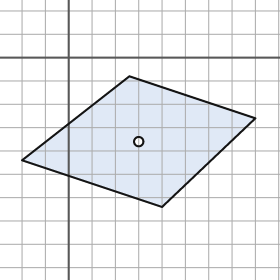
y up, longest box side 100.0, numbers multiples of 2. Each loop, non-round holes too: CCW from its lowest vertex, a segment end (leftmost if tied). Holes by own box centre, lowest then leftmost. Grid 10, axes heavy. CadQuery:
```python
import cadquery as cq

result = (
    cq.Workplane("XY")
    .moveTo(40.0, -64.0)
    .lineTo(80.0, -26.0)
    .lineTo(26.0, -8.0)
    .lineTo(-20.0, -44.0)
    .close()
    .moveTo(30.0, -36.0)
    .circle(2.0)
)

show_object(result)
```